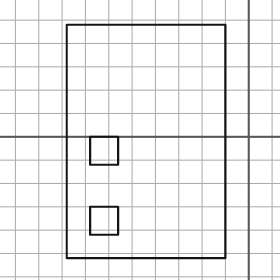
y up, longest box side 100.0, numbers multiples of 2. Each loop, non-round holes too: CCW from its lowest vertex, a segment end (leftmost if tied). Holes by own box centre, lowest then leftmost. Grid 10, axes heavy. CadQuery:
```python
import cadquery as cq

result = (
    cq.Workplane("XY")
    .moveTo(-78.0, -52.0)
    .lineTo(-10.0, -52.0)
    .lineTo(-10.0, 48.0)
    .lineTo(-78.0, 48.0)
    .close()
    .moveTo(-68.0, -42.0)
    .lineTo(-56.0, -42.0)
    .lineTo(-56.0, -30.0)
    .lineTo(-68.0, -30.0)
    .close()
    .moveTo(-68.0, -12.0)
    .lineTo(-56.0, -12.0)
    .lineTo(-56.0, 0.0)
    .lineTo(-68.0, 0.0)
    .close()
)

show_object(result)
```